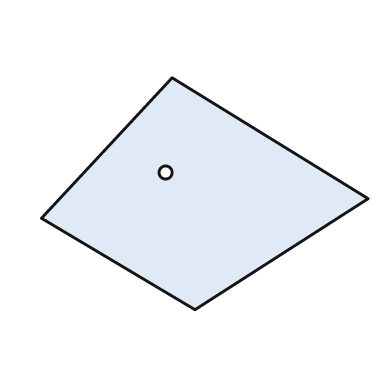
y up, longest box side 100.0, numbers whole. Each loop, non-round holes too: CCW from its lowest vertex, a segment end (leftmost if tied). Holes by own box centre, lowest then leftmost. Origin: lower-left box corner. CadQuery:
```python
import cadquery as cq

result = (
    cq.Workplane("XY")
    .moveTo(47.0, 0.0)
    .lineTo(100.0, 34.0)
    .lineTo(40.0, 71.0)
    .lineTo(0.0, 28.0)
    .close()
    .moveTo(38.0, 42.0)
    .circle(2.0)
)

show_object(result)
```